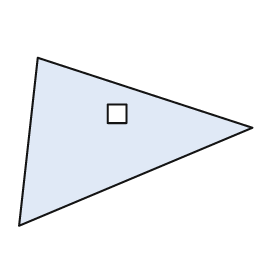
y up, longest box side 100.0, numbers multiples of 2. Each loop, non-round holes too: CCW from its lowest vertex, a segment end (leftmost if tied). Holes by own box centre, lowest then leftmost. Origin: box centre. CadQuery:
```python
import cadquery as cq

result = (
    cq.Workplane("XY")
    .moveTo(-50.0, -36.0)
    .lineTo(50.0, 6.0)
    .lineTo(-42.0, 36.0)
    .close()
    .moveTo(-12.0, 8.0)
    .lineTo(-4.0, 8.0)
    .lineTo(-4.0, 16.0)
    .lineTo(-12.0, 16.0)
    .close()
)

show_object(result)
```